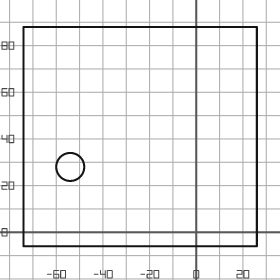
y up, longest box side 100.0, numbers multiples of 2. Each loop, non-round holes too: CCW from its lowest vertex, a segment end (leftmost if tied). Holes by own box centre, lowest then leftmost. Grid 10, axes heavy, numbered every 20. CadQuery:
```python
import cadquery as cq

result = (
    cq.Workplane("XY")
    .moveTo(-74.0, -6.0)
    .lineTo(26.0, -6.0)
    .lineTo(26.0, 88.0)
    .lineTo(-74.0, 88.0)
    .close()
    .moveTo(-54.0, 28.0)
    .circle(6.0)
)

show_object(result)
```